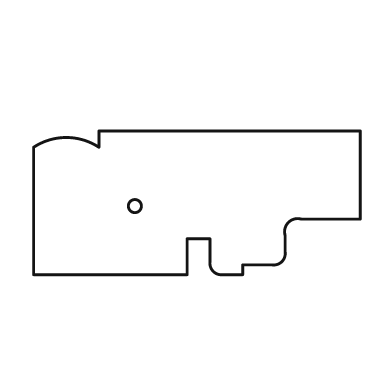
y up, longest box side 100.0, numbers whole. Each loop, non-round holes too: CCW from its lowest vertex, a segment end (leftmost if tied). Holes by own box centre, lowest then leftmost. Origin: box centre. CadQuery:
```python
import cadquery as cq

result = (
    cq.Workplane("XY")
    .moveTo(-50.0, -22.0)
    .lineTo(-3.0, -22.0)
    .lineTo(-3.0, -11.0)
    .lineTo(4.0, -11.0)
    .lineTo(4.0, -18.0)
    .threePointArc((5.0, -21.0), (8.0, -22.0))
    .lineTo(14.0, -22.0)
    .lineTo(14.0, -19.0)
    .lineTo(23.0, -19.0)
    .threePointArc((26.0, -18.0), (27.0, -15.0))
    .lineTo(27.0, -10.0)
    .threePointArc((28.0, -6.0), (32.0, -5.0))
    .lineTo(50.0, -5.0)
    .lineTo(50.0, 22.0)
    .lineTo(-30.0, 22.0)
    .lineTo(-30.0, 17.0)
    .threePointArc((-40.0, 20.0), (-50.0, 17.0))
    .close()
    .moveTo(-19.0, -1.0)
    .circle(2.0)
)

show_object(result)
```